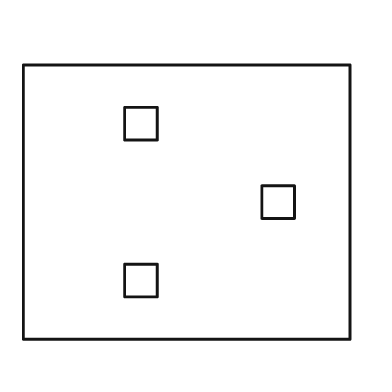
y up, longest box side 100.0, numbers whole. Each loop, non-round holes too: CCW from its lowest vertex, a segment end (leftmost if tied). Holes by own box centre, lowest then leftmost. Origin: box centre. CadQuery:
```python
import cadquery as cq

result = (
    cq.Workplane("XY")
    .moveTo(-50.0, -42.0)
    .lineTo(50.0, -42.0)
    .lineTo(50.0, 42.0)
    .lineTo(-50.0, 42.0)
    .close()
    .moveTo(-19.0, -29.0)
    .lineTo(-9.0, -29.0)
    .lineTo(-9.0, -19.0)
    .lineTo(-19.0, -19.0)
    .close()
    .moveTo(23.0, -5.0)
    .lineTo(33.0, -5.0)
    .lineTo(33.0, 5.0)
    .lineTo(23.0, 5.0)
    .close()
    .moveTo(-19.0, 19.0)
    .lineTo(-9.0, 19.0)
    .lineTo(-9.0, 29.0)
    .lineTo(-19.0, 29.0)
    .close()
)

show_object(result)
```